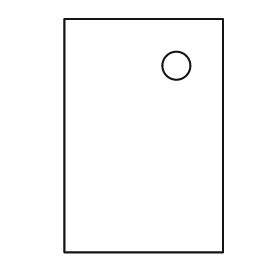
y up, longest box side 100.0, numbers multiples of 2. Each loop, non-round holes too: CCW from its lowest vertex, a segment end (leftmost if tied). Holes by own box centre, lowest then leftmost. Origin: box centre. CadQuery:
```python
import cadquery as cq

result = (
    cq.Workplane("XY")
    .moveTo(-34.0, -50.0)
    .lineTo(34.0, -50.0)
    .lineTo(34.0, 50.0)
    .lineTo(-34.0, 50.0)
    .close()
    .moveTo(14.0, 30.0)
    .circle(6.0)
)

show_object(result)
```